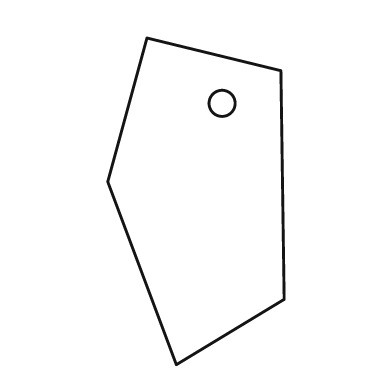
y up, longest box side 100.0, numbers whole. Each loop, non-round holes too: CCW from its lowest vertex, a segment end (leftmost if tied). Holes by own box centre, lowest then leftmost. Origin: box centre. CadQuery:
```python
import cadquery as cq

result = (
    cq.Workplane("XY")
    .moveTo(-6.0, -50.0)
    .lineTo(27.0, -30.0)
    .lineTo(26.0, 40.0)
    .lineTo(-15.0, 50.0)
    .lineTo(-27.0, 6.0)
    .close()
    .moveTo(8.0, 30.0)
    .circle(4.0)
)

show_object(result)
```